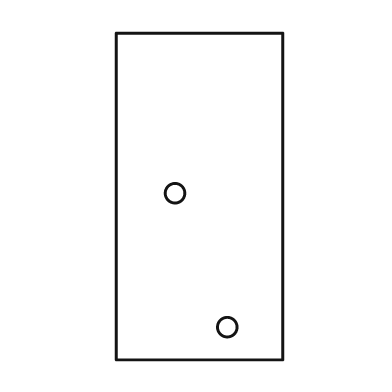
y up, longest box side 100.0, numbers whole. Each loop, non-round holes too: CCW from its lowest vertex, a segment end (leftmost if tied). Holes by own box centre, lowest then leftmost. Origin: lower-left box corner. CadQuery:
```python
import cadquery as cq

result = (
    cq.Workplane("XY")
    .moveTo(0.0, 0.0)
    .lineTo(51.0, 0.0)
    .lineTo(51.0, 100.0)
    .lineTo(0.0, 100.0)
    .close()
    .moveTo(34.0, 10.0)
    .circle(3.0)
    .moveTo(18.0, 51.0)
    .circle(3.0)
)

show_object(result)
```